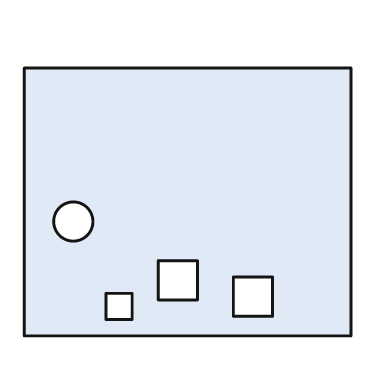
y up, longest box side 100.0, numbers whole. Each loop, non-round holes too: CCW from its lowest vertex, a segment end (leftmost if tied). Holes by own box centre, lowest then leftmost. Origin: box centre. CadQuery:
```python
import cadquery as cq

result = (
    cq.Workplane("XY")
    .moveTo(-50.0, -41.0)
    .lineTo(50.0, -41.0)
    .lineTo(50.0, 41.0)
    .lineTo(-50.0, 41.0)
    .close()
    .moveTo(-25.0, -36.0)
    .lineTo(-17.0, -36.0)
    .lineTo(-17.0, -28.0)
    .lineTo(-25.0, -28.0)
    .close()
    .moveTo(14.0, -35.0)
    .lineTo(26.0, -35.0)
    .lineTo(26.0, -23.0)
    .lineTo(14.0, -23.0)
    .close()
    .moveTo(-9.0, -30.0)
    .lineTo(3.0, -30.0)
    .lineTo(3.0, -18.0)
    .lineTo(-9.0, -18.0)
    .close()
    .moveTo(-35.0, -6.0)
    .circle(6.0)
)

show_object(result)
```